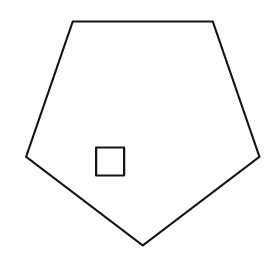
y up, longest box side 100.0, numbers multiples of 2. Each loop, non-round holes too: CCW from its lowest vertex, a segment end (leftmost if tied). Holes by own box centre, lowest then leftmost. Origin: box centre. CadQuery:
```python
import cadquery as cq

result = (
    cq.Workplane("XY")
    .moveTo(0.0, -48.0)
    .lineTo(50.0, -10.0)
    .lineTo(30.0, 48.0)
    .lineTo(-30.0, 48.0)
    .lineTo(-50.0, -10.0)
    .close()
    .moveTo(-20.0, -18.0)
    .lineTo(-8.0, -18.0)
    .lineTo(-8.0, -6.0)
    .lineTo(-20.0, -6.0)
    .close()
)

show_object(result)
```